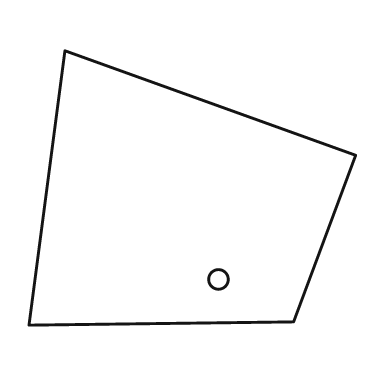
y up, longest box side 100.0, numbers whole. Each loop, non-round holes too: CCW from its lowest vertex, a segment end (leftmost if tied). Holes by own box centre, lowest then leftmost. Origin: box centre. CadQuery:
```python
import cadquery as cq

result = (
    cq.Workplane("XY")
    .moveTo(-50.0, -42.0)
    .lineTo(31.0, -41.0)
    .lineTo(50.0, 10.0)
    .lineTo(-39.0, 42.0)
    .close()
    .moveTo(8.0, -28.0)
    .circle(3.0)
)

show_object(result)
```